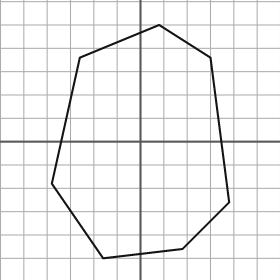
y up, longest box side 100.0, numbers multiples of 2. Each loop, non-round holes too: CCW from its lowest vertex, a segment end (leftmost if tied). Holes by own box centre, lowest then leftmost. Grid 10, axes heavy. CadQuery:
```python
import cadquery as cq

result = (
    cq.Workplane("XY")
    .moveTo(-16.0, -50.0)
    .lineTo(18.0, -46.0)
    .lineTo(38.0, -26.0)
    .lineTo(30.0, 36.0)
    .lineTo(8.0, 50.0)
    .lineTo(-26.0, 36.0)
    .lineTo(-38.0, -18.0)
    .close()
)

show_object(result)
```